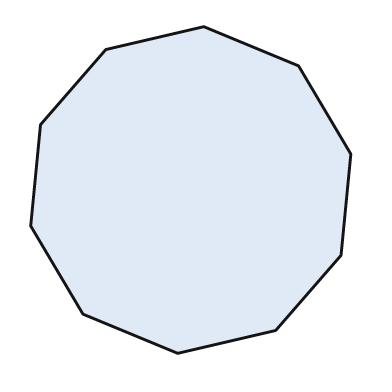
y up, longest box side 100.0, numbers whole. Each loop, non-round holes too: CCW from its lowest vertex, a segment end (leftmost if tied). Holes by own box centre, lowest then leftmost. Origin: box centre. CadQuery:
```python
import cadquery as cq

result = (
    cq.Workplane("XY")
    .moveTo(-4.0, -50.0)
    .lineTo(26.0, -43.0)
    .lineTo(46.0, -20.0)
    .lineTo(49.0, 11.0)
    .lineTo(33.0, 38.0)
    .lineTo(4.0, 50.0)
    .lineTo(-26.0, 43.0)
    .lineTo(-46.0, 20.0)
    .lineTo(-49.0, -11.0)
    .lineTo(-33.0, -38.0)
    .close()
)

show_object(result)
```